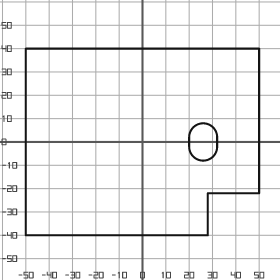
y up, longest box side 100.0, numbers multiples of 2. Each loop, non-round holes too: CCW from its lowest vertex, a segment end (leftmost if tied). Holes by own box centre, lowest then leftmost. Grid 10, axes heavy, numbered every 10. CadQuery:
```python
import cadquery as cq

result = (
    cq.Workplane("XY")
    .moveTo(-50.0, -40.0)
    .lineTo(28.0, -40.0)
    .lineTo(28.0, -22.0)
    .lineTo(50.0, -22.0)
    .lineTo(50.0, 40.0)
    .lineTo(-50.0, 40.0)
    .close()
    .moveTo(20.0, -2.0)
    .threePointArc((26.0, -8.0), (32.0, -2.0))
    .lineTo(32.0, 2.0)
    .threePointArc((26.0, 8.0), (20.0, 2.0))
    .close()
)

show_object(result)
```